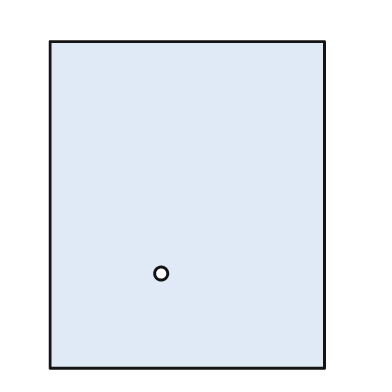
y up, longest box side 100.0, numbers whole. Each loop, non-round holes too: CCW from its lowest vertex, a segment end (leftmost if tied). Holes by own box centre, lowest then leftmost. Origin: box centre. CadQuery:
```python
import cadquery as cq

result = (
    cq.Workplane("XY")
    .moveTo(-42.0, -50.0)
    .lineTo(42.0, -50.0)
    .lineTo(42.0, 50.0)
    .lineTo(-42.0, 50.0)
    .close()
    .moveTo(-8.0, -21.0)
    .circle(2.0)
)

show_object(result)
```